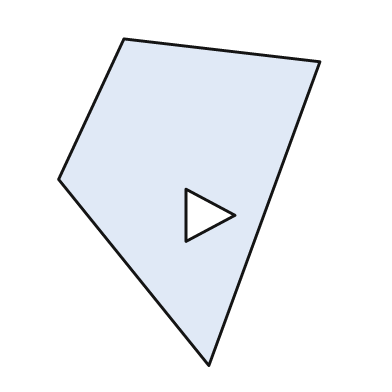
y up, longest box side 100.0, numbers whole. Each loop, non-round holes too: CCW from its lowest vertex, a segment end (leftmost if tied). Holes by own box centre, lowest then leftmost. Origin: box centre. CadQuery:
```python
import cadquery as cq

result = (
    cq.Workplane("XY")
    .moveTo(6.0, -50.0)
    .lineTo(40.0, 43.0)
    .lineTo(-20.0, 50.0)
    .lineTo(-40.0, 7.0)
    .close()
    .moveTo(-1.0, -12.0)
    .lineTo(14.0, -4.0)
    .lineTo(-1.0, 4.0)
    .close()
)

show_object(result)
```